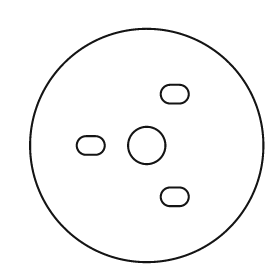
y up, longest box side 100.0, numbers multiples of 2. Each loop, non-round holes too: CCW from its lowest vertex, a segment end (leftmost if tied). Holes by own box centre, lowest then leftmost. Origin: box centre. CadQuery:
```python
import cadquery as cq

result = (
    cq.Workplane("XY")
    .moveTo(0.0, 0.0)
    .circle(50.0)
    .moveTo(10.0, -26.0)
    .lineTo(14.0, -26.0)
    .threePointArc((18.0, -22.0), (14.0, -18.0))
    .lineTo(10.0, -18.0)
    .threePointArc((6.0, -22.0), (10.0, -26.0))
    .close()
    .moveTo(-26.0, -4.0)
    .lineTo(-22.0, -4.0)
    .threePointArc((-18.0, 0.0), (-22.0, 4.0))
    .lineTo(-26.0, 4.0)
    .threePointArc((-30.0, 0.0), (-26.0, -4.0))
    .close()
    .moveTo(0.0, 0.0)
    .circle(8.0)
    .moveTo(10.0, 18.0)
    .lineTo(14.0, 18.0)
    .threePointArc((18.0, 22.0), (14.0, 26.0))
    .lineTo(10.0, 26.0)
    .threePointArc((6.0, 22.0), (10.0, 18.0))
    .close()
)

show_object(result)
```